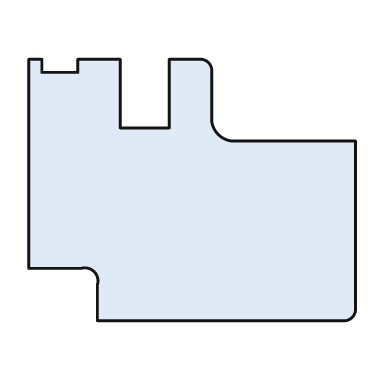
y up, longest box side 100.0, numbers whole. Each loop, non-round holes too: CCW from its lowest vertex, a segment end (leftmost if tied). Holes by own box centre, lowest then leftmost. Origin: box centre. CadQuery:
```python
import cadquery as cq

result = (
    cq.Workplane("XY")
    .moveTo(-29.0, -40.0)
    .lineTo(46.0, -40.0)
    .threePointArc((49.0, -39.0), (50.0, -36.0))
    .lineTo(50.0, 15.0)
    .lineTo(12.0, 15.0)
    .threePointArc((8.0, 17.0), (6.0, 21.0))
    .lineTo(6.0, 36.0)
    .threePointArc((5.0, 39.0), (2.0, 40.0))
    .lineTo(-7.0, 40.0)
    .lineTo(-7.0, 19.0)
    .lineTo(-22.0, 19.0)
    .lineTo(-22.0, 40.0)
    .lineTo(-35.0, 40.0)
    .lineTo(-35.0, 36.0)
    .lineTo(-46.0, 36.0)
    .lineTo(-46.0, 40.0)
    .lineTo(-50.0, 40.0)
    .lineTo(-50.0, -24.0)
    .lineTo(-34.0, -24.0)
    .threePointArc((-30.0, -25.0), (-29.0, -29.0))
    .close()
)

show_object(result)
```